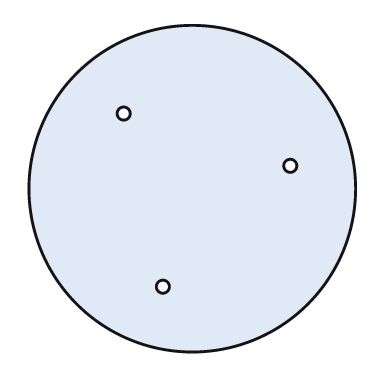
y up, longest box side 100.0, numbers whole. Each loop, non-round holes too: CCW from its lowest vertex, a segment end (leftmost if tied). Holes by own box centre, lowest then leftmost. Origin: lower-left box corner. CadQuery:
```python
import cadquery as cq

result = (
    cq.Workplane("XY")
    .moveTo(50.0, 50.0)
    .circle(50.0)
    .moveTo(41.0, 20.0)
    .circle(2.0)
    .moveTo(80.0, 57.0)
    .circle(2.0)
    .moveTo(29.0, 73.0)
    .circle(2.0)
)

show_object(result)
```